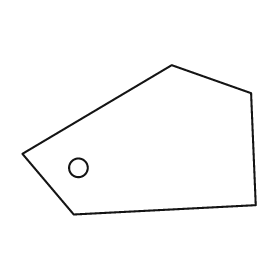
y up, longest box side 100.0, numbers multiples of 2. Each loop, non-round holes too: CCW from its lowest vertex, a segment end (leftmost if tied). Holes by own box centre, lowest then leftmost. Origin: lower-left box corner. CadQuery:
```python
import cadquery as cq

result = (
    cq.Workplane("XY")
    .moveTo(22.0, 0.0)
    .lineTo(100.0, 4.0)
    .lineTo(98.0, 52.0)
    .lineTo(64.0, 64.0)
    .lineTo(0.0, 26.0)
    .close()
    .moveTo(24.0, 20.0)
    .circle(4.0)
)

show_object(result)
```